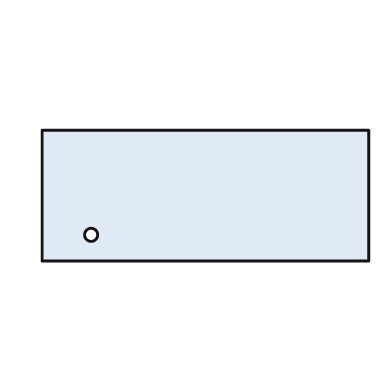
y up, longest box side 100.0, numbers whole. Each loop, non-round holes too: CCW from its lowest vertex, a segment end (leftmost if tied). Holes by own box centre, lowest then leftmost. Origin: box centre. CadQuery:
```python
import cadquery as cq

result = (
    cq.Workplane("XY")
    .moveTo(-50.0, -20.0)
    .lineTo(50.0, -20.0)
    .lineTo(50.0, 20.0)
    .lineTo(-50.0, 20.0)
    .close()
    .moveTo(-35.0, -12.0)
    .circle(2.0)
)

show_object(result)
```